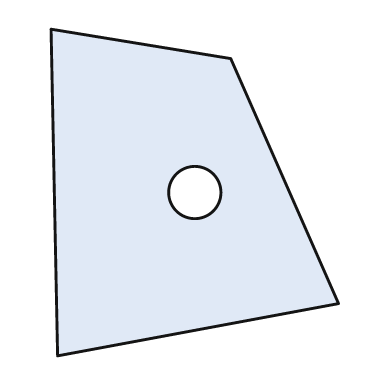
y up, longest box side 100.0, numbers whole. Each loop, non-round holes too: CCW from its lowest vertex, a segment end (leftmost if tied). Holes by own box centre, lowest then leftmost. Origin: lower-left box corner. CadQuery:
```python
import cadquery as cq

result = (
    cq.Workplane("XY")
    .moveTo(2.0, 0.0)
    .lineTo(88.0, 16.0)
    .lineTo(55.0, 91.0)
    .lineTo(0.0, 100.0)
    .close()
    .moveTo(44.0, 50.0)
    .circle(8.0)
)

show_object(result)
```